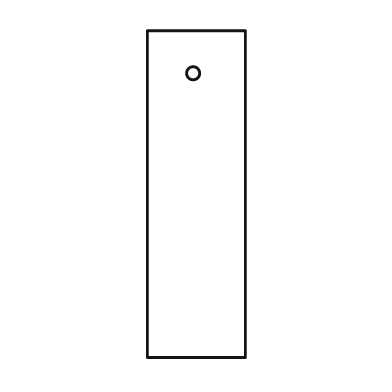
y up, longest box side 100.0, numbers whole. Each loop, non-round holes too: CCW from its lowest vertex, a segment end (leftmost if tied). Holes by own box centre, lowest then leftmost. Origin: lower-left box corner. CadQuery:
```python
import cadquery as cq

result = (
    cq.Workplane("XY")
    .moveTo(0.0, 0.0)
    .lineTo(30.0, 0.0)
    .lineTo(30.0, 100.0)
    .lineTo(0.0, 100.0)
    .close()
    .moveTo(14.0, 87.0)
    .circle(2.0)
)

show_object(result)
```